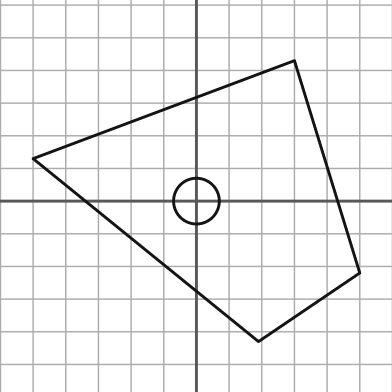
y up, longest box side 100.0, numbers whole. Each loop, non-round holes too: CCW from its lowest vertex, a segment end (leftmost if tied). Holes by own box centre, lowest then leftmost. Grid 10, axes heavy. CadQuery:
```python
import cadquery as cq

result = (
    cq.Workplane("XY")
    .moveTo(19.0, -43.0)
    .lineTo(50.0, -22.0)
    .lineTo(30.0, 43.0)
    .lineTo(-50.0, 13.0)
    .close()
    .moveTo(0.0, 0.0)
    .circle(7.0)
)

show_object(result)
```